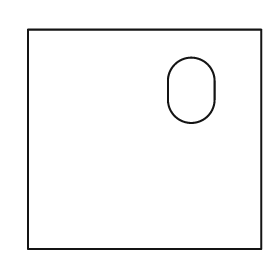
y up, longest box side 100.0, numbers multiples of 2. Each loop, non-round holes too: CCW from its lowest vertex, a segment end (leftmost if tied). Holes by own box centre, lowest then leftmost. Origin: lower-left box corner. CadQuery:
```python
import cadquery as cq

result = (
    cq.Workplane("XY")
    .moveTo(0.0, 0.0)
    .lineTo(100.0, 0.0)
    .lineTo(100.0, 94.0)
    .lineTo(0.0, 94.0)
    .close()
    .moveTo(60.0, 64.0)
    .threePointArc((70.0, 54.0), (80.0, 64.0))
    .lineTo(80.0, 72.0)
    .threePointArc((70.0, 82.0), (60.0, 72.0))
    .close()
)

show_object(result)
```